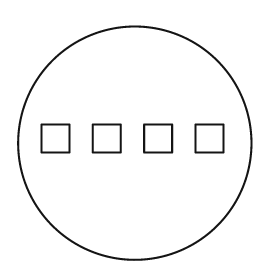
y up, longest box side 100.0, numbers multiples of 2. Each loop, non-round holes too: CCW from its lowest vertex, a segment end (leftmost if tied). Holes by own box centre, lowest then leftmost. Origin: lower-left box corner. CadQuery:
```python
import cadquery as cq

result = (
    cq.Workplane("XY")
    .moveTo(50.0, 50.0)
    .circle(50.0)
    .moveTo(10.0, 46.0)
    .lineTo(22.0, 46.0)
    .lineTo(22.0, 58.0)
    .lineTo(10.0, 58.0)
    .close()
    .moveTo(32.0, 46.0)
    .lineTo(44.0, 46.0)
    .lineTo(44.0, 58.0)
    .lineTo(32.0, 58.0)
    .close()
    .moveTo(54.0, 46.0)
    .lineTo(66.0, 46.0)
    .lineTo(66.0, 58.0)
    .lineTo(54.0, 58.0)
    .close()
    .moveTo(76.0, 46.0)
    .lineTo(88.0, 46.0)
    .lineTo(88.0, 58.0)
    .lineTo(76.0, 58.0)
    .close()
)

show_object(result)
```